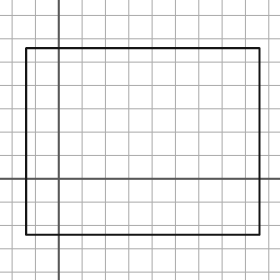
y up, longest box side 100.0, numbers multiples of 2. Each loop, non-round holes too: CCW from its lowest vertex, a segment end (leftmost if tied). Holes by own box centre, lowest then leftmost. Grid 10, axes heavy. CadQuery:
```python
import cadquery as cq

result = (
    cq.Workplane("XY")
    .moveTo(-14.0, -24.0)
    .lineTo(86.0, -24.0)
    .lineTo(86.0, 56.0)
    .lineTo(-14.0, 56.0)
    .close()
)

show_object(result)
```